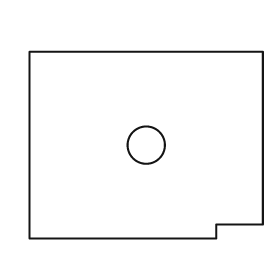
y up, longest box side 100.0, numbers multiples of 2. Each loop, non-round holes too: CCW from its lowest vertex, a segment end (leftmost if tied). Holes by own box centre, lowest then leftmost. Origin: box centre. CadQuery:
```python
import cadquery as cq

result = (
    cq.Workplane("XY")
    .moveTo(-50.0, -40.0)
    .lineTo(30.0, -40.0)
    .lineTo(30.0, -34.0)
    .lineTo(50.0, -34.0)
    .lineTo(50.0, 40.0)
    .lineTo(-50.0, 40.0)
    .close()
    .moveTo(0.0, 0.0)
    .circle(8.0)
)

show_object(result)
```